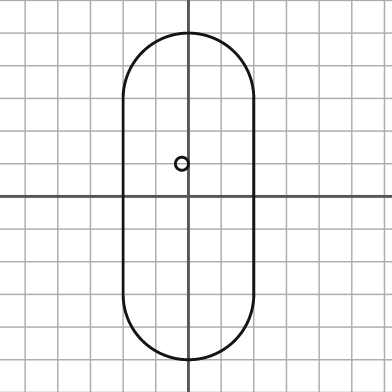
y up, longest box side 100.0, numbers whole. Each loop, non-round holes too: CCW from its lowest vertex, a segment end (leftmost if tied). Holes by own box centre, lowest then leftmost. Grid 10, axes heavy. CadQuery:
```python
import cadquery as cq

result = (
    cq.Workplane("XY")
    .moveTo(-20.0, -30.0)
    .threePointArc((0.0, -50.0), (20.0, -30.0))
    .lineTo(20.0, 30.0)
    .threePointArc((0.0, 50.0), (-20.0, 30.0))
    .close()
    .moveTo(-2.0, 10.0)
    .circle(2.0)
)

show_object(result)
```